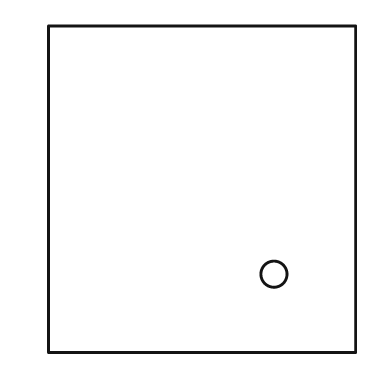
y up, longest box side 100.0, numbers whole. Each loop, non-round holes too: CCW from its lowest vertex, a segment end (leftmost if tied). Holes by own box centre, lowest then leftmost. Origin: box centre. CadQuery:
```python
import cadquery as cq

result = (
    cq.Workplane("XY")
    .moveTo(-47.0, -50.0)
    .lineTo(47.0, -50.0)
    .lineTo(47.0, 50.0)
    .lineTo(-47.0, 50.0)
    .close()
    .moveTo(22.0, -26.0)
    .circle(4.0)
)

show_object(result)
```